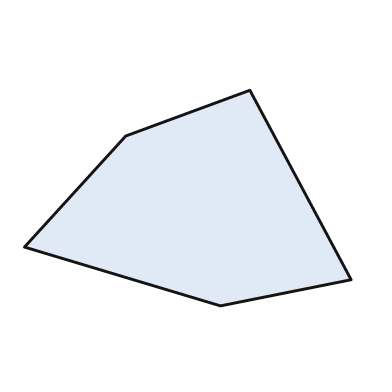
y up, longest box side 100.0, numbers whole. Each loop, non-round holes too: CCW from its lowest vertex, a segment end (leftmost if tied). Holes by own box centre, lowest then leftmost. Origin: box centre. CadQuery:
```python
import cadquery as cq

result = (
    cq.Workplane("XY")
    .moveTo(10.0, -33.0)
    .lineTo(50.0, -25.0)
    .lineTo(19.0, 33.0)
    .lineTo(-19.0, 19.0)
    .lineTo(-50.0, -15.0)
    .close()
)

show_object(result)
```